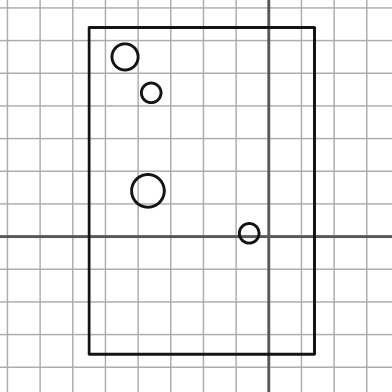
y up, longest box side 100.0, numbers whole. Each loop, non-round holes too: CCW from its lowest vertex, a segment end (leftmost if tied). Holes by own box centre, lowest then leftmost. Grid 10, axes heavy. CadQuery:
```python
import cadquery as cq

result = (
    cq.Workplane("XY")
    .moveTo(-55.0, -36.0)
    .lineTo(14.0, -36.0)
    .lineTo(14.0, 64.0)
    .lineTo(-55.0, 64.0)
    .close()
    .moveTo(-6.0, 1.0)
    .circle(3.0)
    .moveTo(-37.0, 14.0)
    .circle(5.0)
    .moveTo(-36.0, 44.0)
    .circle(3.0)
    .moveTo(-44.0, 55.0)
    .circle(4.0)
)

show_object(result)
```